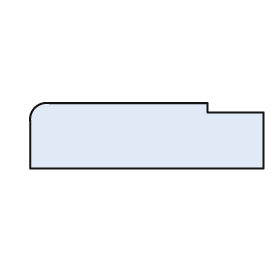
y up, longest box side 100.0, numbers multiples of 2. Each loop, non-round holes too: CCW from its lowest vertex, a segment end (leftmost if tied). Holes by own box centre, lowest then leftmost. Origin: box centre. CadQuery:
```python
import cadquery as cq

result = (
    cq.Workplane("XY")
    .moveTo(-50.0, -14.0)
    .lineTo(50.0, -14.0)
    .lineTo(50.0, 10.0)
    .lineTo(26.0, 10.0)
    .lineTo(26.0, 14.0)
    .lineTo(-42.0, 14.0)
    .threePointArc((-48.0, 12.0), (-50.0, 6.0))
    .close()
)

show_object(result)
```